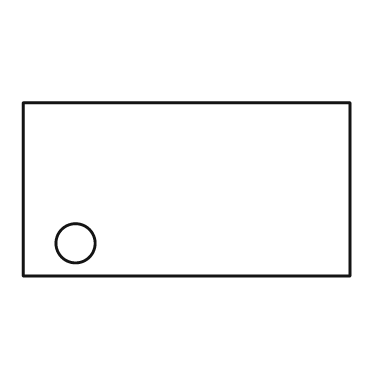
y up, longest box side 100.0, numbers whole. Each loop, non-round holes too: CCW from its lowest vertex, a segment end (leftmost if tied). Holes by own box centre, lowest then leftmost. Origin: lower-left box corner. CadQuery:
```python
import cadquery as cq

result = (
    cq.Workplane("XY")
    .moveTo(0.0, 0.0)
    .lineTo(100.0, 0.0)
    .lineTo(100.0, 53.0)
    .lineTo(0.0, 53.0)
    .close()
    .moveTo(16.0, 10.0)
    .circle(6.0)
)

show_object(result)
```